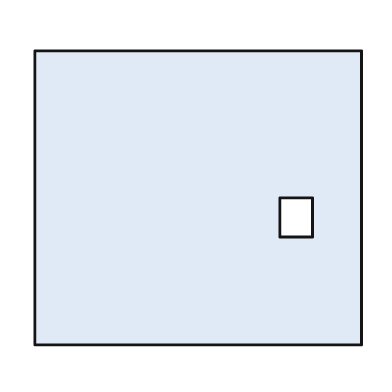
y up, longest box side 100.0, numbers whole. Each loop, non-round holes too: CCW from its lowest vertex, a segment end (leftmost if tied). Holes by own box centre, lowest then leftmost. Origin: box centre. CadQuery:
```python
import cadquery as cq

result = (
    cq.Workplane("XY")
    .moveTo(-50.0, -45.0)
    .lineTo(50.0, -45.0)
    .lineTo(50.0, 45.0)
    .lineTo(-50.0, 45.0)
    .close()
    .moveTo(25.0, -12.0)
    .lineTo(35.0, -12.0)
    .lineTo(35.0, 0.0)
    .lineTo(25.0, 0.0)
    .close()
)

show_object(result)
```